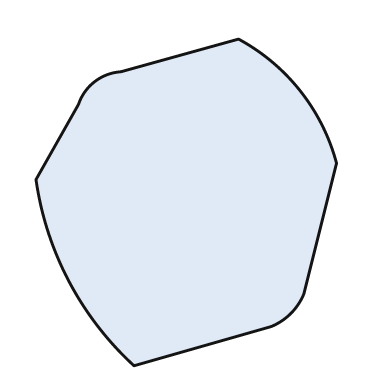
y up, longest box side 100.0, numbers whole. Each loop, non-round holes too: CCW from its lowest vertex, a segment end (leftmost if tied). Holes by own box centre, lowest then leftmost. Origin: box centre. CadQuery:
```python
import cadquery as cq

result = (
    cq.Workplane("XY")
    .moveTo(-16.0, -50.0)
    .lineTo(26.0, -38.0)
    .threePointArc((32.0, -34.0), (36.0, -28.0))
    .lineTo(46.0, 12.0)
    .threePointArc((35.0, 34.0), (16.0, 50.0))
    .lineTo(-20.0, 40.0)
    .threePointArc((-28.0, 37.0), (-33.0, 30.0))
    .lineTo(-46.0, 7.0)
    .threePointArc((-36.0, -24.0), (-16.0, -50.0))
    .close()
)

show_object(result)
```